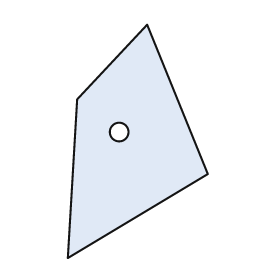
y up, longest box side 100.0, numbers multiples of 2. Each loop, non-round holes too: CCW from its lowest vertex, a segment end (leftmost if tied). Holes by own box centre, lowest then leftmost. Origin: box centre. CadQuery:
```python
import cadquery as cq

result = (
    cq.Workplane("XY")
    .moveTo(-30.0, -50.0)
    .lineTo(30.0, -14.0)
    .lineTo(4.0, 50.0)
    .lineTo(-26.0, 18.0)
    .close()
    .moveTo(-8.0, 4.0)
    .circle(4.0)
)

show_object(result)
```